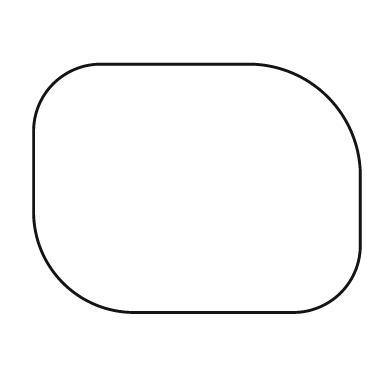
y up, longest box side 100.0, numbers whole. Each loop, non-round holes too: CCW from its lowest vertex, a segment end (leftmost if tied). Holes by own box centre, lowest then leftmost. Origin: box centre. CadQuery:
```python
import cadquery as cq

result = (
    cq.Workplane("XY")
    .moveTo(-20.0, -38.0)
    .lineTo(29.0, -38.0)
    .threePointArc((44.0, -32.0), (50.0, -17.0))
    .lineTo(50.0, 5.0)
    .threePointArc((40.0, 28.0), (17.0, 38.0))
    .lineTo(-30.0, 38.0)
    .threePointArc((-44.0, 32.0), (-50.0, 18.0))
    .lineTo(-50.0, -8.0)
    .threePointArc((-41.0, -29.0), (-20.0, -38.0))
    .close()
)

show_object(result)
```